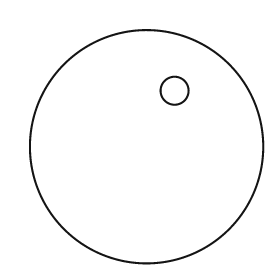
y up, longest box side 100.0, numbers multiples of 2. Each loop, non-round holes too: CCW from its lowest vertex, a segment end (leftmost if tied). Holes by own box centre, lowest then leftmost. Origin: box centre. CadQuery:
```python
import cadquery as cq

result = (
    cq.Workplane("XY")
    .moveTo(0.0, 0.0)
    .circle(50.0)
    .moveTo(12.0, 24.0)
    .circle(6.0)
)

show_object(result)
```